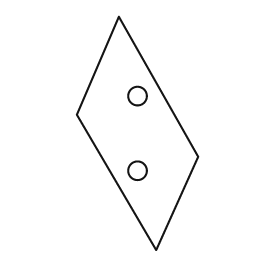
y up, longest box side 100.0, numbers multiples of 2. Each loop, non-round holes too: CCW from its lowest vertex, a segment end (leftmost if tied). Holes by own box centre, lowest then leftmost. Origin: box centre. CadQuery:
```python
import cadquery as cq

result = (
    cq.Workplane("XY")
    .moveTo(8.0, -50.0)
    .lineTo(26.0, -10.0)
    .lineTo(-8.0, 50.0)
    .lineTo(-26.0, 8.0)
    .close()
    .moveTo(0.0, -16.0)
    .circle(4.0)
    .moveTo(0.0, 16.0)
    .circle(4.0)
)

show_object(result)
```